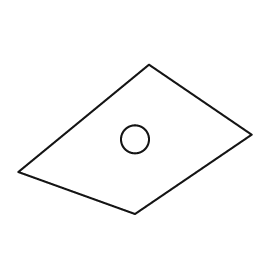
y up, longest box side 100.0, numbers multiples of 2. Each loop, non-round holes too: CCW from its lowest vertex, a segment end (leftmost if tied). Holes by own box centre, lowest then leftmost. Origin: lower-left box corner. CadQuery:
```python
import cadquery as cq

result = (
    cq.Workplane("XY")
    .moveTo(50.0, 0.0)
    .lineTo(100.0, 34.0)
    .lineTo(56.0, 64.0)
    .lineTo(0.0, 18.0)
    .close()
    .moveTo(50.0, 32.0)
    .circle(6.0)
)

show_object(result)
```